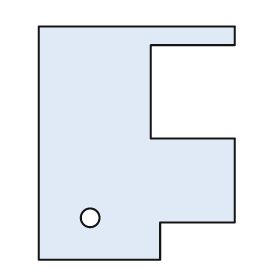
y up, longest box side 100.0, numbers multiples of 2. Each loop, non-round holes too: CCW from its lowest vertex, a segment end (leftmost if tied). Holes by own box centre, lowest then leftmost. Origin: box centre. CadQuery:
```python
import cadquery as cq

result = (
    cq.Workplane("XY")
    .moveTo(-42.0, -50.0)
    .lineTo(10.0, -50.0)
    .lineTo(10.0, -34.0)
    .lineTo(42.0, -34.0)
    .lineTo(42.0, 2.0)
    .lineTo(6.0, 2.0)
    .lineTo(6.0, 42.0)
    .lineTo(42.0, 42.0)
    .lineTo(42.0, 50.0)
    .lineTo(-42.0, 50.0)
    .close()
    .moveTo(-20.0, -32.0)
    .circle(4.0)
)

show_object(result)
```